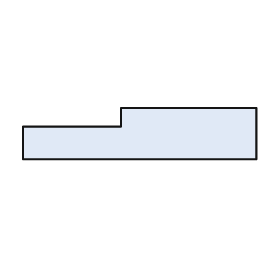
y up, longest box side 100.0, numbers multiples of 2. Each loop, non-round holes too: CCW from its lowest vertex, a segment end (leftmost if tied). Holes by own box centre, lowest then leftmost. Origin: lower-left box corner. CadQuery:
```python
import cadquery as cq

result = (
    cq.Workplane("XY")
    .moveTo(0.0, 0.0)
    .lineTo(100.0, 0.0)
    .lineTo(100.0, 22.0)
    .lineTo(42.0, 22.0)
    .lineTo(42.0, 14.0)
    .lineTo(0.0, 14.0)
    .close()
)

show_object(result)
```